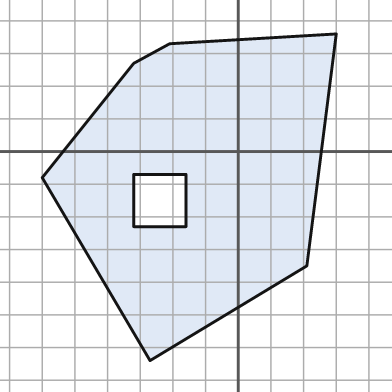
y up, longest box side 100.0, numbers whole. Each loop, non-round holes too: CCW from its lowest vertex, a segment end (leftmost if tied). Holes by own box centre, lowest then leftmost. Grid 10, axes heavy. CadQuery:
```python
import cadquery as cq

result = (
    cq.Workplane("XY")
    .moveTo(-27.0, -64.0)
    .lineTo(21.0, -35.0)
    .lineTo(30.0, 36.0)
    .lineTo(-21.0, 33.0)
    .lineTo(-32.0, 27.0)
    .lineTo(-60.0, -8.0)
    .close()
    .moveTo(-32.0, -23.0)
    .lineTo(-16.0, -23.0)
    .lineTo(-16.0, -7.0)
    .lineTo(-32.0, -7.0)
    .close()
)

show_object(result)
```